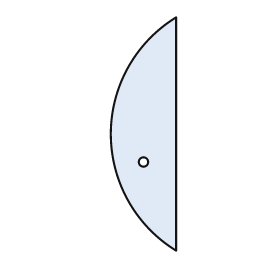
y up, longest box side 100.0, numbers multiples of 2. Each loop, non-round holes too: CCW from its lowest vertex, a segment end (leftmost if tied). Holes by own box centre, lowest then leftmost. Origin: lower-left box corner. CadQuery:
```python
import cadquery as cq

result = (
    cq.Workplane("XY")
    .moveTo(28.0, 0.0)
    .lineTo(28.0, 100.0)
    .threePointArc((0.0, 50.0), (28.0, 0.0))
    .close()
    .moveTo(14.0, 38.0)
    .circle(2.0)
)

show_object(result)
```